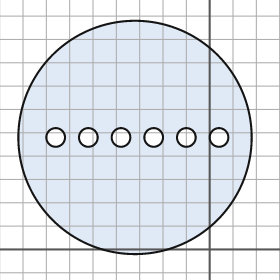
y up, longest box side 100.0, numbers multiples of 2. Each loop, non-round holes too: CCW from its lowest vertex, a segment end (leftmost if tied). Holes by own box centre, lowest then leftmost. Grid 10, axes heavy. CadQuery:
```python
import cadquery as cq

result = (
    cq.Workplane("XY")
    .moveTo(-32.0, 48.0)
    .circle(50.0)
    .moveTo(-66.0, 48.0)
    .circle(4.0)
    .moveTo(-52.0, 48.0)
    .circle(4.0)
    .moveTo(-38.0, 48.0)
    .circle(4.0)
    .moveTo(-24.0, 48.0)
    .circle(4.0)
    .moveTo(-10.0, 48.0)
    .circle(4.0)
    .moveTo(4.0, 48.0)
    .circle(4.0)
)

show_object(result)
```